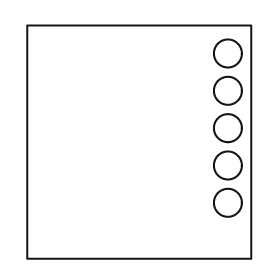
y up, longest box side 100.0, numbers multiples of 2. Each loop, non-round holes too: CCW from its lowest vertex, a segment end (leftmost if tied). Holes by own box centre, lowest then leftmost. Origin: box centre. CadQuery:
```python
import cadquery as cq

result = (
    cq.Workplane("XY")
    .moveTo(-48.0, -50.0)
    .lineTo(48.0, -50.0)
    .lineTo(48.0, 50.0)
    .lineTo(-48.0, 50.0)
    .close()
    .moveTo(38.0, -26.0)
    .circle(6.0)
    .moveTo(38.0, -10.0)
    .circle(6.0)
    .moveTo(38.0, 6.0)
    .circle(6.0)
    .moveTo(38.0, 22.0)
    .circle(6.0)
    .moveTo(38.0, 38.0)
    .circle(6.0)
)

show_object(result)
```